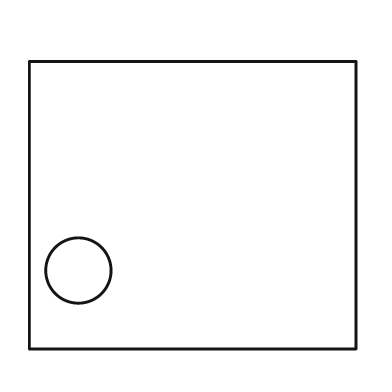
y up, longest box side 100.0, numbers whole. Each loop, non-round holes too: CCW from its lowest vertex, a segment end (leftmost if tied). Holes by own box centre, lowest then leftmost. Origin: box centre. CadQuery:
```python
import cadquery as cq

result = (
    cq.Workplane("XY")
    .moveTo(-50.0, -44.0)
    .lineTo(50.0, -44.0)
    .lineTo(50.0, 44.0)
    .lineTo(-50.0, 44.0)
    .close()
    .moveTo(-35.0, -20.0)
    .circle(10.0)
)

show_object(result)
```